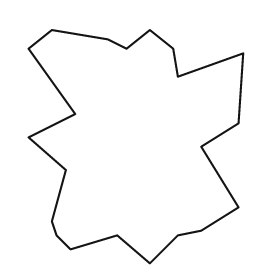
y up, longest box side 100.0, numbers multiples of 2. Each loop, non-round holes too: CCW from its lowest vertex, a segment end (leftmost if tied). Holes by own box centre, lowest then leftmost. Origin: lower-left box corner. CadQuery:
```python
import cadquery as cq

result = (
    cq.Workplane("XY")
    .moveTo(52.0, 0.0)
    .lineTo(64.0, 12.0)
    .lineTo(74.0, 14.0)
    .lineTo(90.0, 24.0)
    .lineTo(74.0, 50.0)
    .lineTo(90.0, 60.0)
    .lineTo(92.0, 90.0)
    .lineTo(64.0, 80.0)
    .lineTo(62.0, 92.0)
    .lineTo(52.0, 100.0)
    .lineTo(42.0, 92.0)
    .lineTo(34.0, 96.0)
    .lineTo(10.0, 100.0)
    .lineTo(0.0, 92.0)
    .lineTo(20.0, 64.0)
    .lineTo(0.0, 54.0)
    .lineTo(16.0, 40.0)
    .lineTo(10.0, 18.0)
    .lineTo(12.0, 12.0)
    .lineTo(18.0, 6.0)
    .lineTo(38.0, 12.0)
    .close()
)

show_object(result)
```